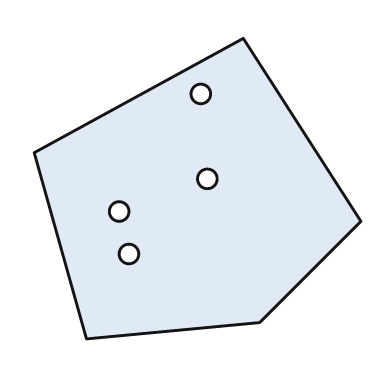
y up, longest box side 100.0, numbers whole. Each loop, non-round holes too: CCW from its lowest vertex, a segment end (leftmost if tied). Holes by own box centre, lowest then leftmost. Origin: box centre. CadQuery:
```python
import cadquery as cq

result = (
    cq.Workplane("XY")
    .moveTo(-34.0, -46.0)
    .lineTo(19.0, -41.0)
    .lineTo(50.0, -10.0)
    .lineTo(14.0, 46.0)
    .lineTo(-50.0, 11.0)
    .close()
    .moveTo(-21.0, -20.0)
    .circle(3.0)
    .moveTo(-24.0, -7.0)
    .circle(3.0)
    .moveTo(3.0, 3.0)
    .circle(3.0)
    .moveTo(1.0, 29.0)
    .circle(3.0)
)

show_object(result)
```